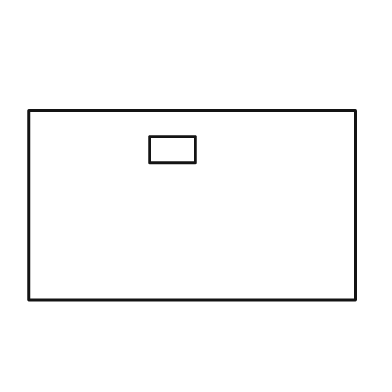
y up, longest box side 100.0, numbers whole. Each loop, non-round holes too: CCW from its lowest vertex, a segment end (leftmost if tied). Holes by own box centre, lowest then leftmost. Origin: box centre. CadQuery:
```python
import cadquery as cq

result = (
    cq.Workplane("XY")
    .moveTo(-50.0, -29.0)
    .lineTo(50.0, -29.0)
    .lineTo(50.0, 29.0)
    .lineTo(-50.0, 29.0)
    .close()
    .moveTo(-13.0, 13.0)
    .lineTo(1.0, 13.0)
    .lineTo(1.0, 21.0)
    .lineTo(-13.0, 21.0)
    .close()
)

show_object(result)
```